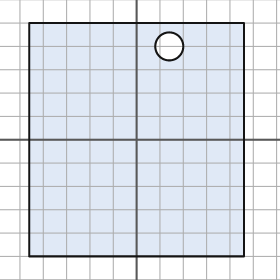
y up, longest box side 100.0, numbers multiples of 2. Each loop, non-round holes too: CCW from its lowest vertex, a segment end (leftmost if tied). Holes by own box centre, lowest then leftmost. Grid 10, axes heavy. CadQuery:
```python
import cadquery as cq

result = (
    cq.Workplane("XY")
    .moveTo(-46.0, -50.0)
    .lineTo(46.0, -50.0)
    .lineTo(46.0, 50.0)
    .lineTo(-46.0, 50.0)
    .close()
    .moveTo(14.0, 40.0)
    .circle(6.0)
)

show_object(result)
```